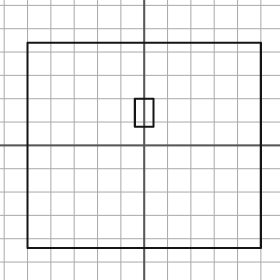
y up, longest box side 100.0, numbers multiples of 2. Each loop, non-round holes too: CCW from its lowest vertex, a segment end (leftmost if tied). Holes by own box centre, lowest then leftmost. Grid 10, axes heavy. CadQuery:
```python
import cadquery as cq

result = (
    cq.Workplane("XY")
    .moveTo(-50.0, -44.0)
    .lineTo(50.0, -44.0)
    .lineTo(50.0, 44.0)
    .lineTo(-50.0, 44.0)
    .close()
    .moveTo(-4.0, 8.0)
    .lineTo(4.0, 8.0)
    .lineTo(4.0, 20.0)
    .lineTo(-4.0, 20.0)
    .close()
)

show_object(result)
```